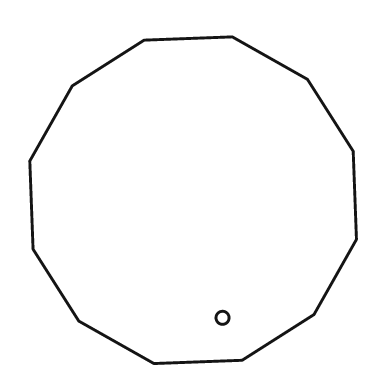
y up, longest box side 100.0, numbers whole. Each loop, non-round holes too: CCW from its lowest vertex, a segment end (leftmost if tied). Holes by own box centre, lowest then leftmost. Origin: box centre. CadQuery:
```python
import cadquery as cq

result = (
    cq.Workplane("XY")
    .moveTo(-12.0, -50.0)
    .lineTo(15.0, -49.0)
    .lineTo(37.0, -35.0)
    .lineTo(50.0, -12.0)
    .lineTo(49.0, 15.0)
    .lineTo(35.0, 37.0)
    .lineTo(12.0, 50.0)
    .lineTo(-15.0, 49.0)
    .lineTo(-37.0, 35.0)
    .lineTo(-50.0, 12.0)
    .lineTo(-49.0, -15.0)
    .lineTo(-35.0, -37.0)
    .close()
    .moveTo(9.0, -36.0)
    .circle(2.0)
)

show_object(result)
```